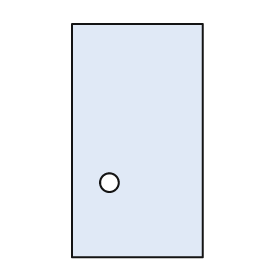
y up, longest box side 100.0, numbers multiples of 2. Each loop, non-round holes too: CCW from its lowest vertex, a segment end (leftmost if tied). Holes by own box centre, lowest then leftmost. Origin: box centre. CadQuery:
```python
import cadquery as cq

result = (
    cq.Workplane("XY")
    .moveTo(-28.0, -50.0)
    .lineTo(28.0, -50.0)
    .lineTo(28.0, 50.0)
    .lineTo(-28.0, 50.0)
    .close()
    .moveTo(-12.0, -18.0)
    .circle(4.0)
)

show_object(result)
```